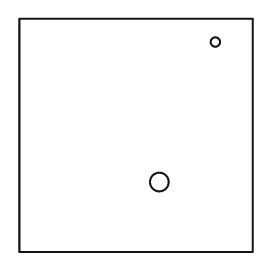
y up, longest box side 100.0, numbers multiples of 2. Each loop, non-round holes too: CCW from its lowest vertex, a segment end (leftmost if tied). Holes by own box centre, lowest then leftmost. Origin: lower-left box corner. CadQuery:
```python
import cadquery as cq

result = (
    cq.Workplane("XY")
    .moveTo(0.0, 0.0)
    .lineTo(100.0, 0.0)
    .lineTo(100.0, 100.0)
    .lineTo(0.0, 100.0)
    .close()
    .moveTo(60.0, 30.0)
    .circle(4.0)
    .moveTo(84.0, 90.0)
    .circle(2.0)
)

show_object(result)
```